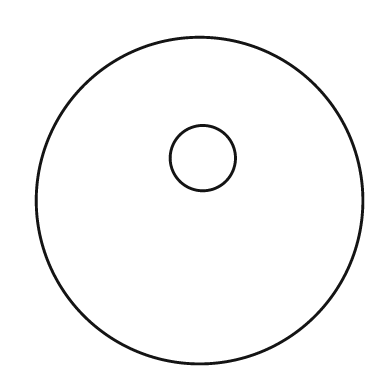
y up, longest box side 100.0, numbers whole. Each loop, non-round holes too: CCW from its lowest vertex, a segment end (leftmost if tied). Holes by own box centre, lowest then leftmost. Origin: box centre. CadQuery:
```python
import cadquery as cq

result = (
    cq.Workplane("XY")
    .moveTo(0.0, 0.0)
    .circle(50.0)
    .moveTo(1.0, 13.0)
    .circle(10.0)
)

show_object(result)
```